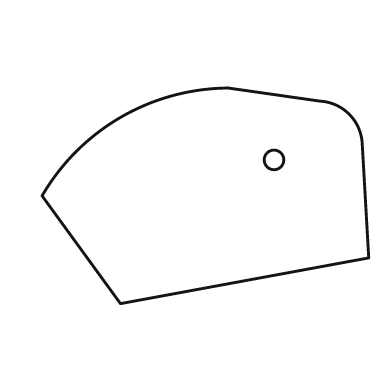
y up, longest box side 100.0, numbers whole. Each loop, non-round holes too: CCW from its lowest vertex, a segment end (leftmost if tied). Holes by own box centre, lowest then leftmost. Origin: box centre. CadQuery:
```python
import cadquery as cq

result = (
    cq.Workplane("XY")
    .moveTo(-26.0, -33.0)
    .lineTo(50.0, -19.0)
    .lineTo(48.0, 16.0)
    .threePointArc((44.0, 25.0), (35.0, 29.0))
    .lineTo(7.0, 33.0)
    .threePointArc((-26.0, 24.0), (-50.0, 0.0))
    .close()
    .moveTo(21.0, 11.0)
    .circle(3.0)
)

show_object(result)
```